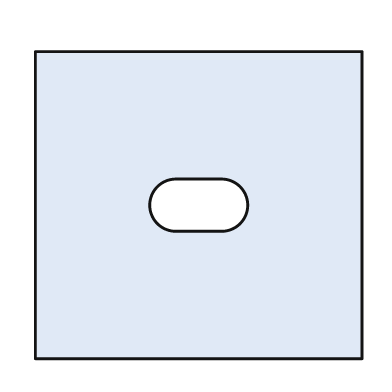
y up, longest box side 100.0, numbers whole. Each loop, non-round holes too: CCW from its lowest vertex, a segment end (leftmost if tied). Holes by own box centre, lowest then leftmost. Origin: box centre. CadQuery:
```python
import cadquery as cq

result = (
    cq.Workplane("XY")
    .moveTo(-50.0, -47.0)
    .lineTo(50.0, -47.0)
    .lineTo(50.0, 47.0)
    .lineTo(-50.0, 47.0)
    .close()
    .moveTo(-7.0, -8.0)
    .lineTo(7.0, -8.0)
    .threePointArc((15.0, 0.0), (7.0, 8.0))
    .lineTo(-7.0, 8.0)
    .threePointArc((-15.0, 0.0), (-7.0, -8.0))
    .close()
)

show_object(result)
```